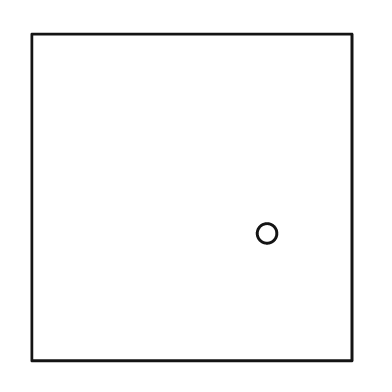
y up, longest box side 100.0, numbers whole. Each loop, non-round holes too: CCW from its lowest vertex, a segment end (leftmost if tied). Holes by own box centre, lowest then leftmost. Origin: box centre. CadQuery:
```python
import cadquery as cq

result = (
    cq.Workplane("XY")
    .moveTo(-49.0, -50.0)
    .lineTo(49.0, -50.0)
    .lineTo(49.0, 50.0)
    .lineTo(-49.0, 50.0)
    .close()
    .moveTo(23.0, -11.0)
    .circle(3.0)
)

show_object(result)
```